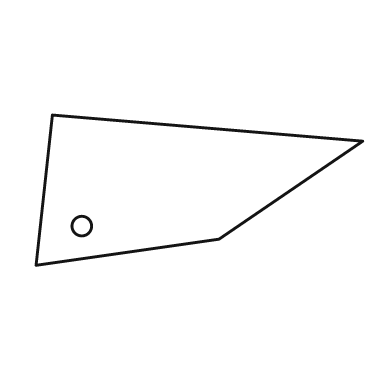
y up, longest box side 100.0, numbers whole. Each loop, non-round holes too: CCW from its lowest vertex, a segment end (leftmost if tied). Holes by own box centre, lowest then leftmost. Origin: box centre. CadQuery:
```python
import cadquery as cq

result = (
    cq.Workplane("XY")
    .moveTo(-50.0, -23.0)
    .lineTo(6.0, -15.0)
    .lineTo(50.0, 15.0)
    .lineTo(-45.0, 23.0)
    .close()
    .moveTo(-36.0, -11.0)
    .circle(3.0)
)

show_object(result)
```